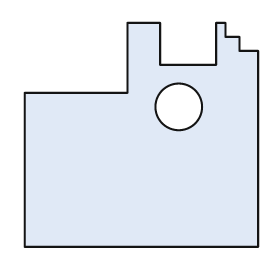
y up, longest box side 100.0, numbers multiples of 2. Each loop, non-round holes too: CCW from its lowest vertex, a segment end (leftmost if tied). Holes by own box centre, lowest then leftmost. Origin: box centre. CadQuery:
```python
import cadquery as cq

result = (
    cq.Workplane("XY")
    .moveTo(-50.0, -48.0)
    .lineTo(50.0, -48.0)
    .lineTo(50.0, 36.0)
    .lineTo(42.0, 36.0)
    .lineTo(42.0, 42.0)
    .lineTo(36.0, 42.0)
    .lineTo(36.0, 48.0)
    .lineTo(32.0, 48.0)
    .lineTo(32.0, 30.0)
    .lineTo(8.0, 30.0)
    .lineTo(8.0, 48.0)
    .lineTo(-6.0, 48.0)
    .lineTo(-6.0, 18.0)
    .lineTo(-50.0, 18.0)
    .close()
    .moveTo(16.0, 12.0)
    .circle(10.0)
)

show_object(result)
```